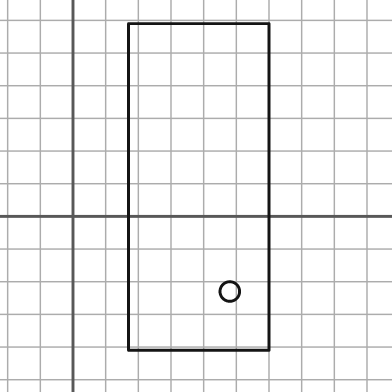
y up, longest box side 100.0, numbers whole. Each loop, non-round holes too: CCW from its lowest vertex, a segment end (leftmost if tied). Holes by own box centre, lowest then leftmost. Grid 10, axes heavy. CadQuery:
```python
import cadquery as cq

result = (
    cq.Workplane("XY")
    .moveTo(17.0, -41.0)
    .lineTo(60.0, -41.0)
    .lineTo(60.0, 59.0)
    .lineTo(17.0, 59.0)
    .close()
    .moveTo(48.0, -23.0)
    .circle(3.0)
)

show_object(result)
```